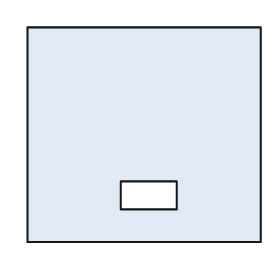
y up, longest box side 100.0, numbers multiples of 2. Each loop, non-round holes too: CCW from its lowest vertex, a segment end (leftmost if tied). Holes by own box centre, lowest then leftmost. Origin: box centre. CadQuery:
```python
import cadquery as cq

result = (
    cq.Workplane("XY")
    .moveTo(-50.0, -46.0)
    .lineTo(50.0, -46.0)
    .lineTo(50.0, 46.0)
    .lineTo(-50.0, 46.0)
    .close()
    .moveTo(-10.0, -32.0)
    .lineTo(14.0, -32.0)
    .lineTo(14.0, -20.0)
    .lineTo(-10.0, -20.0)
    .close()
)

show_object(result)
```